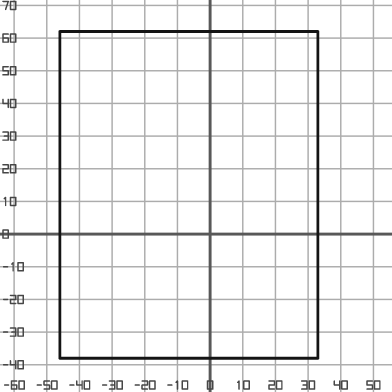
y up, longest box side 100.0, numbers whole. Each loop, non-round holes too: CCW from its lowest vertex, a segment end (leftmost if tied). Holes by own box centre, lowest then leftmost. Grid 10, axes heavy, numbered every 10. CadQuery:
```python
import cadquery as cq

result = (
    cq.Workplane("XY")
    .moveTo(-46.0, -38.0)
    .lineTo(33.0, -38.0)
    .lineTo(33.0, 62.0)
    .lineTo(-46.0, 62.0)
    .close()
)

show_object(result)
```